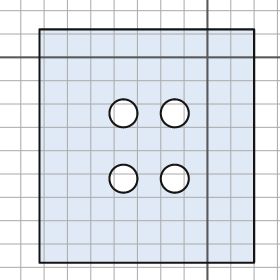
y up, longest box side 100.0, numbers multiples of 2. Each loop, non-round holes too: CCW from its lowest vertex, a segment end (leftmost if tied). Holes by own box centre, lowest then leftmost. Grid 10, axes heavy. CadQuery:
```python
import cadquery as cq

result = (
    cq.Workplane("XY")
    .moveTo(-72.0, -88.0)
    .lineTo(20.0, -88.0)
    .lineTo(20.0, 12.0)
    .lineTo(-72.0, 12.0)
    .close()
    .moveTo(-36.0, -52.0)
    .circle(6.0)
    .moveTo(-14.0, -52.0)
    .circle(6.0)
    .moveTo(-36.0, -24.0)
    .circle(6.0)
    .moveTo(-14.0, -24.0)
    .circle(6.0)
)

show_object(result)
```